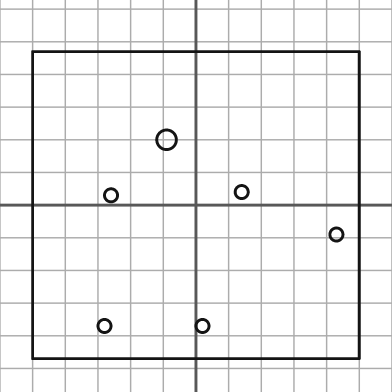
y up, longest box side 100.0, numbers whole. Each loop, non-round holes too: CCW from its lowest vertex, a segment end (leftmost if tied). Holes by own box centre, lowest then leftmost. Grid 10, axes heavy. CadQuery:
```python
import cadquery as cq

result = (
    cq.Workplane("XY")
    .moveTo(-50.0, -47.0)
    .lineTo(50.0, -47.0)
    .lineTo(50.0, 47.0)
    .lineTo(-50.0, 47.0)
    .close()
    .moveTo(-28.0, -37.0)
    .circle(2.0)
    .moveTo(2.0, -37.0)
    .circle(2.0)
    .moveTo(43.0, -9.0)
    .circle(2.0)
    .moveTo(-26.0, 3.0)
    .circle(2.0)
    .moveTo(14.0, 4.0)
    .circle(2.0)
    .moveTo(-9.0, 20.0)
    .circle(3.0)
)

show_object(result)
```